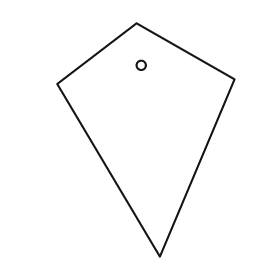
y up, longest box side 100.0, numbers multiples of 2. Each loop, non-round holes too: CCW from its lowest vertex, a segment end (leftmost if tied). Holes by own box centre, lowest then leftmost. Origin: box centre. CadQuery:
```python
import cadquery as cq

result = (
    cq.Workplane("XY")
    .moveTo(6.0, -50.0)
    .lineTo(38.0, 26.0)
    .lineTo(-4.0, 50.0)
    .lineTo(-38.0, 24.0)
    .close()
    .moveTo(-2.0, 32.0)
    .circle(2.0)
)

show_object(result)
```